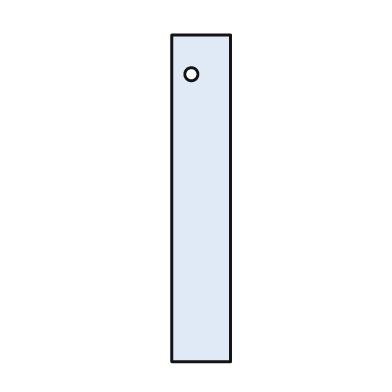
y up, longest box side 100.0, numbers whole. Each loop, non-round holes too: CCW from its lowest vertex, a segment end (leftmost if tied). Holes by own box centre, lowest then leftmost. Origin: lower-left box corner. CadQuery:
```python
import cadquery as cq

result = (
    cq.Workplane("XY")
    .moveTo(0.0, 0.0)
    .lineTo(18.0, 0.0)
    .lineTo(18.0, 100.0)
    .lineTo(0.0, 100.0)
    .close()
    .moveTo(6.0, 88.0)
    .circle(2.0)
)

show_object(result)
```